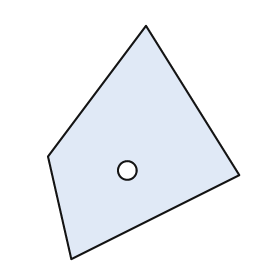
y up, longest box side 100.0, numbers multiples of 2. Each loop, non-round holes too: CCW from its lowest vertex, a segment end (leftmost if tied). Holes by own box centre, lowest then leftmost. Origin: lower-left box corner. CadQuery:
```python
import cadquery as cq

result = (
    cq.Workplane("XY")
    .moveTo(10.0, 0.0)
    .lineTo(82.0, 36.0)
    .lineTo(42.0, 100.0)
    .lineTo(0.0, 44.0)
    .close()
    .moveTo(34.0, 38.0)
    .circle(4.0)
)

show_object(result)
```